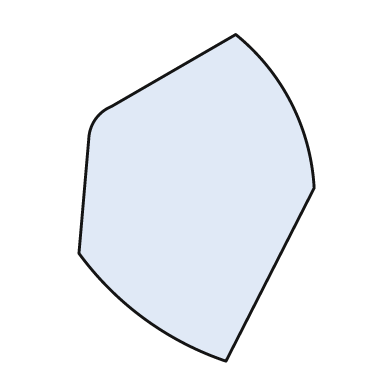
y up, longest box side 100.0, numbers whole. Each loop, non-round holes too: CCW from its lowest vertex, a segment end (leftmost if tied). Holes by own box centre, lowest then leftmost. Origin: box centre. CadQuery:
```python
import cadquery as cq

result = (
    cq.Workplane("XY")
    .moveTo(9.0, -50.0)
    .lineTo(36.0, 3.0)
    .threePointArc((29.0, 29.0), (12.0, 50.0))
    .lineTo(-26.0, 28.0)
    .threePointArc((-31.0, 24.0), (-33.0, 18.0))
    .lineTo(-36.0, -17.0)
    .threePointArc((-16.0, -37.0), (9.0, -50.0))
    .close()
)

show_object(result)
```